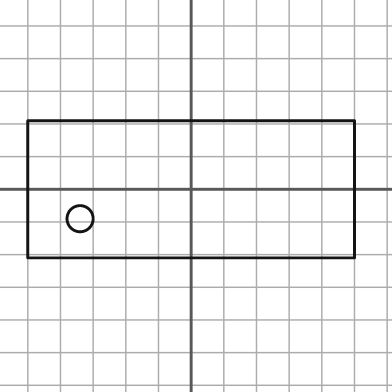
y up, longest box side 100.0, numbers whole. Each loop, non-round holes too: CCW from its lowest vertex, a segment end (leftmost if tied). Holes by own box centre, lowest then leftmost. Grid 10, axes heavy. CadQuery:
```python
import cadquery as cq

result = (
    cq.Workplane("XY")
    .moveTo(-50.0, -21.0)
    .lineTo(50.0, -21.0)
    .lineTo(50.0, 21.0)
    .lineTo(-50.0, 21.0)
    .close()
    .moveTo(-34.0, -9.0)
    .circle(4.0)
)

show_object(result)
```